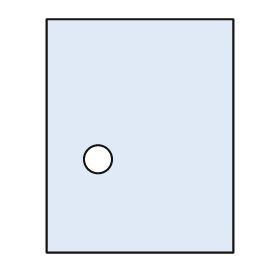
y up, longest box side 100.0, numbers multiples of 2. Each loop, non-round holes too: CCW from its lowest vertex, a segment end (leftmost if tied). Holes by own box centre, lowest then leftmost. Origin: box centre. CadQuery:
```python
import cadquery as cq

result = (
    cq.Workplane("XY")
    .moveTo(-40.0, -50.0)
    .lineTo(40.0, -50.0)
    .lineTo(40.0, 50.0)
    .lineTo(-40.0, 50.0)
    .close()
    .moveTo(-18.0, -10.0)
    .circle(6.0)
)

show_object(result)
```